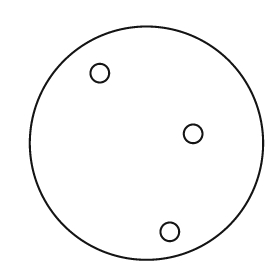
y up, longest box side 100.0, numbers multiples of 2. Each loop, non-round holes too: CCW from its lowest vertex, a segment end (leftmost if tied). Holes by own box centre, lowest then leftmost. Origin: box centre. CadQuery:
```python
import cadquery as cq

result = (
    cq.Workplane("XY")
    .moveTo(0.0, 0.0)
    .circle(50.0)
    .moveTo(10.0, -38.0)
    .circle(4.0)
    .moveTo(20.0, 4.0)
    .circle(4.0)
    .moveTo(-20.0, 30.0)
    .circle(4.0)
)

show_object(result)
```